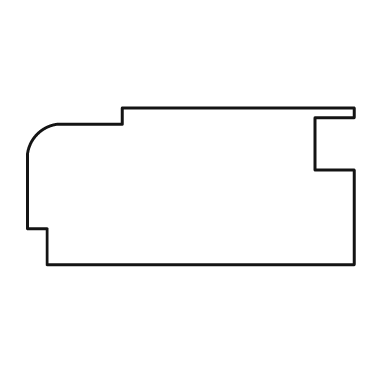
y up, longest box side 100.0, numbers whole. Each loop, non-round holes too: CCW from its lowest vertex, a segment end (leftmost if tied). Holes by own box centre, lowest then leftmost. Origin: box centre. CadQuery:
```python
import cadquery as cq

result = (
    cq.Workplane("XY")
    .moveTo(-44.0, -24.0)
    .lineTo(50.0, -24.0)
    .lineTo(50.0, 5.0)
    .lineTo(38.0, 5.0)
    .lineTo(38.0, 21.0)
    .lineTo(50.0, 21.0)
    .lineTo(50.0, 24.0)
    .lineTo(-21.0, 24.0)
    .lineTo(-21.0, 19.0)
    .lineTo(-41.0, 19.0)
    .threePointArc((-47.0, 16.0), (-50.0, 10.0))
    .lineTo(-50.0, -13.0)
    .lineTo(-44.0, -13.0)
    .close()
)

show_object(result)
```